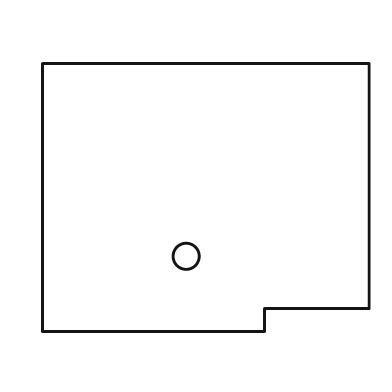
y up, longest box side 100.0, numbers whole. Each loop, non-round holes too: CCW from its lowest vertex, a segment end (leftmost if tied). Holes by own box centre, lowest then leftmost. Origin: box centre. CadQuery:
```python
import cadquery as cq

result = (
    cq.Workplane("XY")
    .moveTo(-50.0, -41.0)
    .lineTo(18.0, -41.0)
    .lineTo(18.0, -34.0)
    .lineTo(50.0, -34.0)
    .lineTo(50.0, 41.0)
    .lineTo(-50.0, 41.0)
    .close()
    .moveTo(-6.0, -18.0)
    .circle(4.0)
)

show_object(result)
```